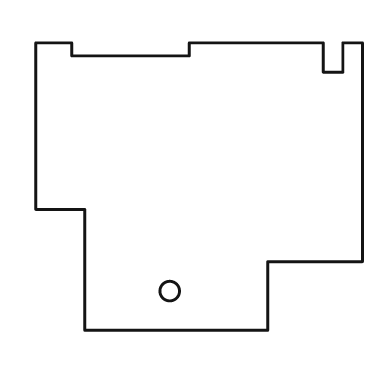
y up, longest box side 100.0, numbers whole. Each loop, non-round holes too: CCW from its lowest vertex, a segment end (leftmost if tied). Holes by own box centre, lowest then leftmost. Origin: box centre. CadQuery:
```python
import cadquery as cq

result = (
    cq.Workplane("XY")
    .moveTo(-35.0, -44.0)
    .lineTo(21.0, -44.0)
    .lineTo(21.0, -23.0)
    .lineTo(50.0, -23.0)
    .lineTo(50.0, 44.0)
    .lineTo(44.0, 44.0)
    .lineTo(44.0, 35.0)
    .lineTo(38.0, 35.0)
    .lineTo(38.0, 44.0)
    .lineTo(-3.0, 44.0)
    .lineTo(-3.0, 40.0)
    .lineTo(-39.0, 40.0)
    .lineTo(-39.0, 44.0)
    .lineTo(-50.0, 44.0)
    .lineTo(-50.0, -7.0)
    .lineTo(-35.0, -7.0)
    .close()
    .moveTo(-9.0, -32.0)
    .circle(3.0)
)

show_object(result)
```